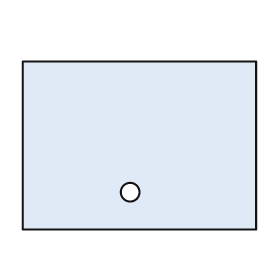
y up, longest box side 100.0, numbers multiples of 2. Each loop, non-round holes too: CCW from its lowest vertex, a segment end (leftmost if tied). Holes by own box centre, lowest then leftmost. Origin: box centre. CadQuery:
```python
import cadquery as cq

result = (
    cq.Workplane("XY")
    .moveTo(-50.0, -36.0)
    .lineTo(50.0, -36.0)
    .lineTo(50.0, 36.0)
    .lineTo(-50.0, 36.0)
    .close()
    .moveTo(-4.0, -20.0)
    .circle(4.0)
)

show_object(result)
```